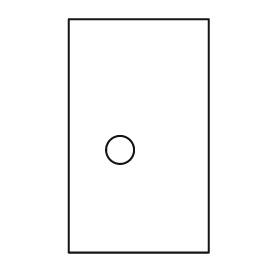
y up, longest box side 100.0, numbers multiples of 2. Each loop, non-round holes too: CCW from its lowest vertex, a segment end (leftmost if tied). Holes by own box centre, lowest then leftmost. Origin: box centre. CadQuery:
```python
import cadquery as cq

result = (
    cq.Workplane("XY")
    .moveTo(-30.0, -50.0)
    .lineTo(30.0, -50.0)
    .lineTo(30.0, 50.0)
    .lineTo(-30.0, 50.0)
    .close()
    .moveTo(-8.0, -6.0)
    .circle(6.0)
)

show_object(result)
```